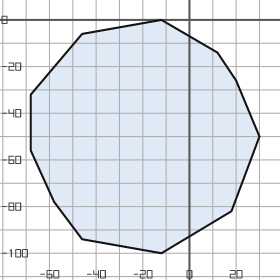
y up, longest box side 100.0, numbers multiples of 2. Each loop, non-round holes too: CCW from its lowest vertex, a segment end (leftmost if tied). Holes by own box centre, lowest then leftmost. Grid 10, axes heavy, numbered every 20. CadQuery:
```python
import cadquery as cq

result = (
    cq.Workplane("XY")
    .moveTo(-12.0, -100.0)
    .lineTo(18.0, -82.0)
    .lineTo(30.0, -50.0)
    .lineTo(20.0, -26.0)
    .lineTo(12.0, -14.0)
    .lineTo(-12.0, 0.0)
    .lineTo(-46.0, -6.0)
    .lineTo(-68.0, -32.0)
    .lineTo(-68.0, -56.0)
    .lineTo(-58.0, -78.0)
    .lineTo(-46.0, -94.0)
    .close()
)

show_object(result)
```